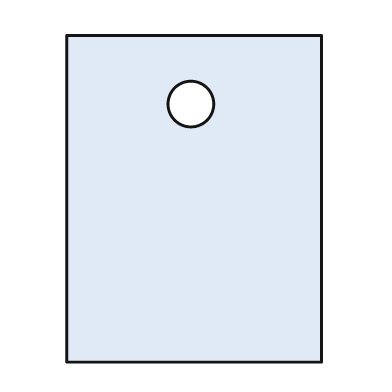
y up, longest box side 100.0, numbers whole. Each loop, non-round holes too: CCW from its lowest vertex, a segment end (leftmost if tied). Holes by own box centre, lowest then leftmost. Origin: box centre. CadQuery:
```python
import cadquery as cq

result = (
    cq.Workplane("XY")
    .moveTo(-39.0, -50.0)
    .lineTo(39.0, -50.0)
    .lineTo(39.0, 50.0)
    .lineTo(-39.0, 50.0)
    .close()
    .moveTo(-1.0, 29.0)
    .circle(7.0)
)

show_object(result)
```